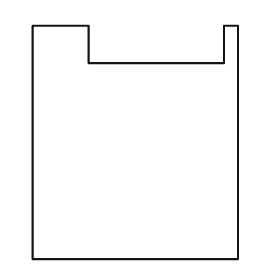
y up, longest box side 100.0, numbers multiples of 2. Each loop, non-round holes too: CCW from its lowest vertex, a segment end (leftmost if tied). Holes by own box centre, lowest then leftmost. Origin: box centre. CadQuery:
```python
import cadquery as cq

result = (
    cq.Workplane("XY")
    .moveTo(-44.0, -50.0)
    .lineTo(44.0, -50.0)
    .lineTo(44.0, 50.0)
    .lineTo(38.0, 50.0)
    .lineTo(38.0, 34.0)
    .lineTo(-20.0, 34.0)
    .lineTo(-20.0, 50.0)
    .lineTo(-44.0, 50.0)
    .close()
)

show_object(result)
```